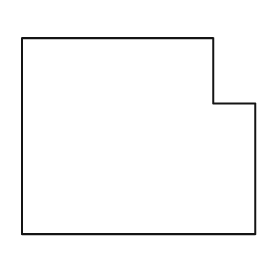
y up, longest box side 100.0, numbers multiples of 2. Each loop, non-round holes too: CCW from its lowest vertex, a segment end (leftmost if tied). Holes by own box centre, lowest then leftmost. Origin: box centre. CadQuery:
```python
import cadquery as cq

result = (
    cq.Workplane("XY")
    .moveTo(-50.0, -42.0)
    .lineTo(50.0, -42.0)
    .lineTo(50.0, 14.0)
    .lineTo(32.0, 14.0)
    .lineTo(32.0, 42.0)
    .lineTo(-50.0, 42.0)
    .close()
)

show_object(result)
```